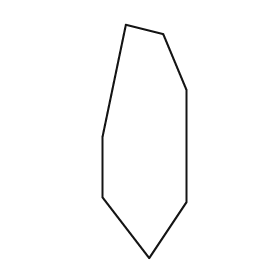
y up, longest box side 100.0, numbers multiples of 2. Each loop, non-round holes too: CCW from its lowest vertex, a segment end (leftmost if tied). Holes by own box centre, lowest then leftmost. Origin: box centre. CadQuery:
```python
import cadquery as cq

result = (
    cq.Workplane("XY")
    .moveTo(2.0, -50.0)
    .lineTo(18.0, -26.0)
    .lineTo(18.0, 22.0)
    .lineTo(8.0, 46.0)
    .lineTo(-8.0, 50.0)
    .lineTo(-18.0, 2.0)
    .lineTo(-18.0, -24.0)
    .close()
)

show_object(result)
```